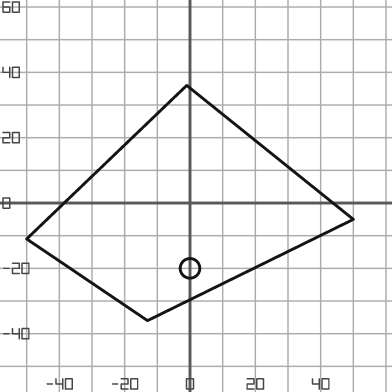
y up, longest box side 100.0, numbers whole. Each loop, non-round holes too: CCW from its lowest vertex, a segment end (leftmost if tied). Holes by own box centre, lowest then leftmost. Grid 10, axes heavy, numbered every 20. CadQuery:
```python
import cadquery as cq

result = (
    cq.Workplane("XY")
    .moveTo(-13.0, -36.0)
    .lineTo(50.0, -5.0)
    .lineTo(-1.0, 36.0)
    .lineTo(-50.0, -11.0)
    .close()
    .moveTo(0.0, -20.0)
    .circle(3.0)
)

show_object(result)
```